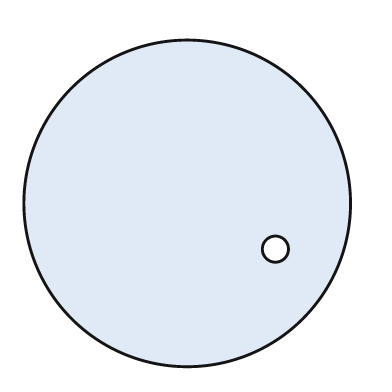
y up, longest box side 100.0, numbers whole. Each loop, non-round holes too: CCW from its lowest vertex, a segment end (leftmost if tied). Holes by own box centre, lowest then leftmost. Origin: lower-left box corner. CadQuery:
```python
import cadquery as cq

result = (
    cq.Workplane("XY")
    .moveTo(50.0, 50.0)
    .circle(50.0)
    .moveTo(77.0, 36.0)
    .circle(4.0)
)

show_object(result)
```